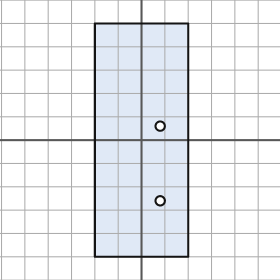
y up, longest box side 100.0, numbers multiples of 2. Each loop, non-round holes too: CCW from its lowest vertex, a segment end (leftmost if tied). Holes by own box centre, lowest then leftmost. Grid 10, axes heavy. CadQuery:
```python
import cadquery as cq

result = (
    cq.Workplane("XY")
    .moveTo(-20.0, -50.0)
    .lineTo(20.0, -50.0)
    .lineTo(20.0, 50.0)
    .lineTo(-20.0, 50.0)
    .close()
    .moveTo(8.0, -26.0)
    .circle(2.0)
    .moveTo(8.0, 6.0)
    .circle(2.0)
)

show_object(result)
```